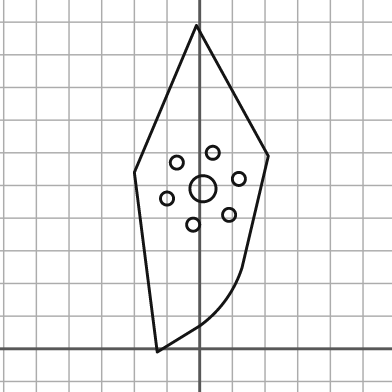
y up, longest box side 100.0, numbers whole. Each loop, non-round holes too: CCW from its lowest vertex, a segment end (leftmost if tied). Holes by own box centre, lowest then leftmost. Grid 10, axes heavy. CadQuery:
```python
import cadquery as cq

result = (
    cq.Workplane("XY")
    .moveTo(-13.0, -1.0)
    .lineTo(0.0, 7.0)
    .threePointArc((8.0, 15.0), (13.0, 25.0))
    .lineTo(21.0, 59.0)
    .lineTo(-1.0, 99.0)
    .lineTo(-20.0, 54.0)
    .close()
    .moveTo(-2.0, 38.0)
    .circle(2.0)
    .moveTo(9.0, 41.0)
    .circle(2.0)
    .moveTo(-10.0, 46.0)
    .circle(2.0)
    .moveTo(1.0, 49.0)
    .circle(4.0)
    .moveTo(12.0, 52.0)
    .circle(2.0)
    .moveTo(-7.0, 57.0)
    .circle(2.0)
    .moveTo(4.0, 60.0)
    .circle(2.0)
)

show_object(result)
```